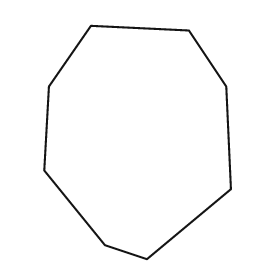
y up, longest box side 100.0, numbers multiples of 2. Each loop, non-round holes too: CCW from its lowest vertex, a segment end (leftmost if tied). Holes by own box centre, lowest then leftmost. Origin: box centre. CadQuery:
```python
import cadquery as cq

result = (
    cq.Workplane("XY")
    .moveTo(4.0, -50.0)
    .lineTo(40.0, -20.0)
    .lineTo(38.0, 24.0)
    .lineTo(22.0, 48.0)
    .lineTo(-20.0, 50.0)
    .lineTo(-38.0, 24.0)
    .lineTo(-40.0, -12.0)
    .lineTo(-14.0, -44.0)
    .close()
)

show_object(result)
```